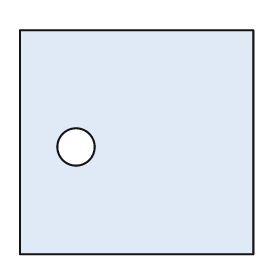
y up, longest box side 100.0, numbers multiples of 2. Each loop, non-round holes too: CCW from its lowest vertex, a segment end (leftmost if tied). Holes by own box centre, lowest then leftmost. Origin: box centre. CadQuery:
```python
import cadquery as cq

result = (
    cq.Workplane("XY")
    .moveTo(-50.0, -48.0)
    .lineTo(50.0, -48.0)
    .lineTo(50.0, 48.0)
    .lineTo(-50.0, 48.0)
    .close()
    .moveTo(-26.0, -2.0)
    .circle(8.0)
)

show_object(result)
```